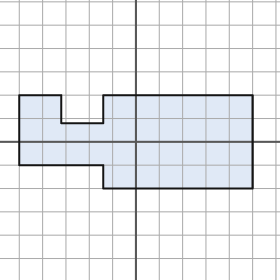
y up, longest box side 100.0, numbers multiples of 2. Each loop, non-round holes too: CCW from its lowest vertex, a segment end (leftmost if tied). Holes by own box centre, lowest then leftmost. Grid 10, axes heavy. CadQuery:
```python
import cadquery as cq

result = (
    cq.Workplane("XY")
    .moveTo(-14.0, -20.0)
    .lineTo(50.0, -20.0)
    .lineTo(50.0, 20.0)
    .lineTo(-14.0, 20.0)
    .lineTo(-14.0, 8.0)
    .lineTo(-32.0, 8.0)
    .lineTo(-32.0, 20.0)
    .lineTo(-50.0, 20.0)
    .lineTo(-50.0, -10.0)
    .lineTo(-14.0, -10.0)
    .close()
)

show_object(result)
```